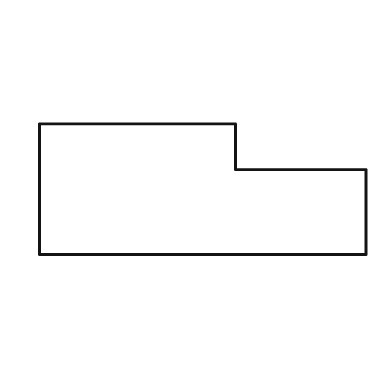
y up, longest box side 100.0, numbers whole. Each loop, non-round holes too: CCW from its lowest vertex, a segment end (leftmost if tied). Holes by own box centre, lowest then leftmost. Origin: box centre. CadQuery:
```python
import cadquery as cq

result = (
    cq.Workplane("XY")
    .moveTo(-50.0, -20.0)
    .lineTo(50.0, -20.0)
    .lineTo(50.0, 6.0)
    .lineTo(10.0, 6.0)
    .lineTo(10.0, 20.0)
    .lineTo(-50.0, 20.0)
    .close()
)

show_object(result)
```